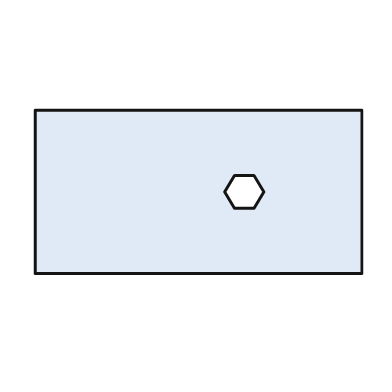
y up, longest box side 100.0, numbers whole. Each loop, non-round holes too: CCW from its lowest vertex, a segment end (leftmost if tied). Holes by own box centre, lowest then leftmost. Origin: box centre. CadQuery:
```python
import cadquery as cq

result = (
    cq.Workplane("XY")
    .moveTo(-50.0, -25.0)
    .lineTo(50.0, -25.0)
    .lineTo(50.0, 25.0)
    .lineTo(-50.0, 25.0)
    .close()
    .moveTo(11.0, -5.0)
    .lineTo(17.0, -5.0)
    .lineTo(20.0, 0.0)
    .lineTo(17.0, 5.0)
    .lineTo(11.0, 5.0)
    .lineTo(8.0, 0.0)
    .close()
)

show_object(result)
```